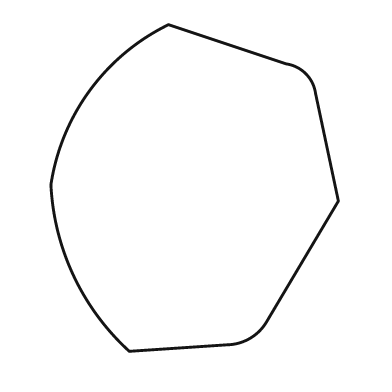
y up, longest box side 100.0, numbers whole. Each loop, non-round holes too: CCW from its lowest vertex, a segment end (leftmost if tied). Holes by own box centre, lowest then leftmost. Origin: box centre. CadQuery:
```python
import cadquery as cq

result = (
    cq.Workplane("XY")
    .moveTo(-20.0, -50.0)
    .lineTo(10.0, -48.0)
    .threePointArc((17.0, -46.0), (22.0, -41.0))
    .lineTo(44.0, -4.0)
    .lineTo(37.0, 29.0)
    .threePointArc((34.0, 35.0), (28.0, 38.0))
    .lineTo(-8.0, 50.0)
    .threePointArc((-32.0, 30.0), (-44.0, 1.0))
    .threePointArc((-37.0, -27.0), (-20.0, -50.0))
    .close()
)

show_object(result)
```